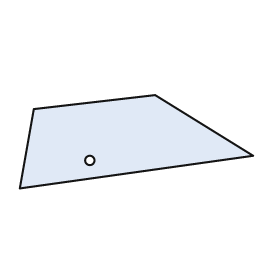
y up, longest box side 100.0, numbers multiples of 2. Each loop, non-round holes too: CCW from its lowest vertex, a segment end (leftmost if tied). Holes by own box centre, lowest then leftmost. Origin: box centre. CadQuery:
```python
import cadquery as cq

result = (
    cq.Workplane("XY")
    .moveTo(-50.0, -20.0)
    .lineTo(50.0, -6.0)
    .lineTo(8.0, 20.0)
    .lineTo(-44.0, 14.0)
    .close()
    .moveTo(-20.0, -8.0)
    .circle(2.0)
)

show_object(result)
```